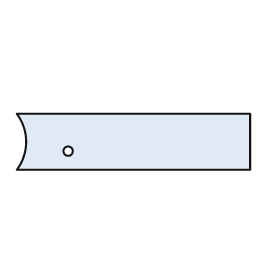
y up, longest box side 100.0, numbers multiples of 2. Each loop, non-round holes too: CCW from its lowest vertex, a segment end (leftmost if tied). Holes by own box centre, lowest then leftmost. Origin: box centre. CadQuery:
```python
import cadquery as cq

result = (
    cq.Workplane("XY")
    .moveTo(-50.0, -12.0)
    .lineTo(50.0, -12.0)
    .lineTo(50.0, 12.0)
    .lineTo(-50.0, 12.0)
    .threePointArc((-46.0, 0.0), (-50.0, -12.0))
    .close()
    .moveTo(-28.0, -4.0)
    .circle(2.0)
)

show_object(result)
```